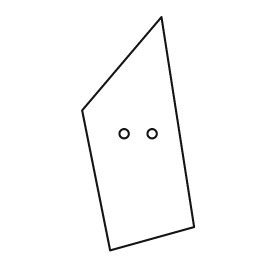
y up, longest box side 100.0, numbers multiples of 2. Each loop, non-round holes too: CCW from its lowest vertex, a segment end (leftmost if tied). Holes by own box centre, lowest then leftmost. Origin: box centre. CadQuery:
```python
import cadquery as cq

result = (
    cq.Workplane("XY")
    .moveTo(-12.0, -50.0)
    .lineTo(24.0, -40.0)
    .lineTo(10.0, 50.0)
    .lineTo(-24.0, 10.0)
    .close()
    .moveTo(-6.0, 0.0)
    .circle(2.0)
    .moveTo(6.0, 0.0)
    .circle(2.0)
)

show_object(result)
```